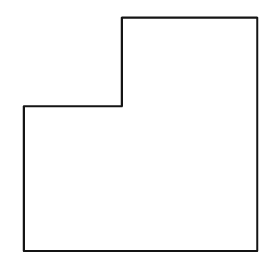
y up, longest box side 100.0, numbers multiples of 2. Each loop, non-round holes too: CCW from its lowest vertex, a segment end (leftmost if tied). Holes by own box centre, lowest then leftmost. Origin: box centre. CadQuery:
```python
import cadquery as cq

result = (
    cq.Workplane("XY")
    .moveTo(-50.0, -50.0)
    .lineTo(50.0, -50.0)
    .lineTo(50.0, 50.0)
    .lineTo(-8.0, 50.0)
    .lineTo(-8.0, 12.0)
    .lineTo(-50.0, 12.0)
    .close()
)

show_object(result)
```